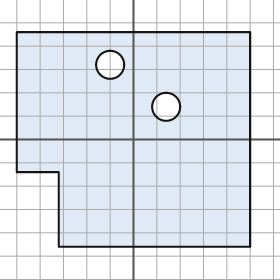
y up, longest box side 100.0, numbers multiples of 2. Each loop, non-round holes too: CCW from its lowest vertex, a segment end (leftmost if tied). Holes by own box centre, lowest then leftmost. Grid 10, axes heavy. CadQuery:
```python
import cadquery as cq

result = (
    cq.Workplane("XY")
    .moveTo(-32.0, -46.0)
    .lineTo(50.0, -46.0)
    .lineTo(50.0, 46.0)
    .lineTo(-50.0, 46.0)
    .lineTo(-50.0, -14.0)
    .lineTo(-32.0, -14.0)
    .close()
    .moveTo(14.0, 14.0)
    .circle(6.0)
    .moveTo(-10.0, 32.0)
    .circle(6.0)
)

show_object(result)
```